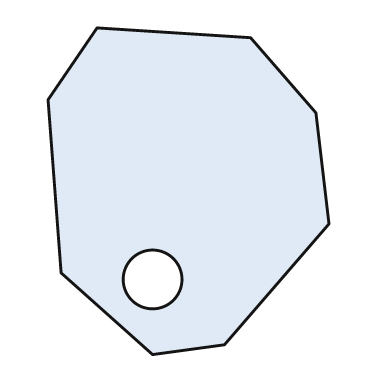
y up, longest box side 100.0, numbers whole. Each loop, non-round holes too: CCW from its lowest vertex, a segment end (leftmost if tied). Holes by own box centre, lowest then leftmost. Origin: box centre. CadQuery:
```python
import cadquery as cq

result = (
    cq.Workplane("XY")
    .moveTo(-11.0, -50.0)
    .lineTo(11.0, -47.0)
    .lineTo(43.0, -10.0)
    .lineTo(39.0, 24.0)
    .lineTo(19.0, 47.0)
    .lineTo(-28.0, 50.0)
    .lineTo(-43.0, 28.0)
    .lineTo(-39.0, -25.0)
    .close()
    .moveTo(-11.0, -27.0)
    .circle(9.0)
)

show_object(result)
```